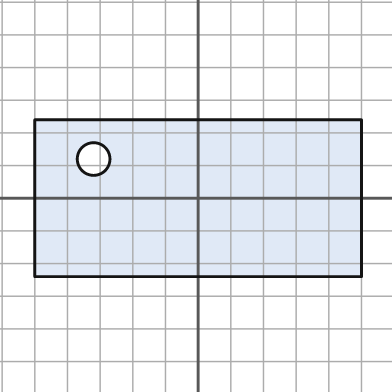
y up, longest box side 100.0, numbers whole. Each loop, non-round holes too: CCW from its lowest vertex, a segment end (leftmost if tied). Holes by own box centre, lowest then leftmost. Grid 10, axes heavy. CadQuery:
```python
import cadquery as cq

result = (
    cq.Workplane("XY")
    .moveTo(-50.0, -24.0)
    .lineTo(50.0, -24.0)
    .lineTo(50.0, 24.0)
    .lineTo(-50.0, 24.0)
    .close()
    .moveTo(-32.0, 12.0)
    .circle(5.0)
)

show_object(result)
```